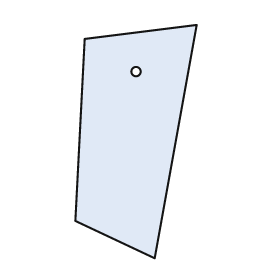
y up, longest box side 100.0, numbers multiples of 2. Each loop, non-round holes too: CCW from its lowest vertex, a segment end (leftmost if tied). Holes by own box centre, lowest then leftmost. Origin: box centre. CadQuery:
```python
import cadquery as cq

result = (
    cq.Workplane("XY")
    .moveTo(8.0, -50.0)
    .lineTo(26.0, 50.0)
    .lineTo(-22.0, 44.0)
    .lineTo(-26.0, -34.0)
    .close()
    .moveTo(0.0, 30.0)
    .circle(2.0)
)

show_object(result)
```